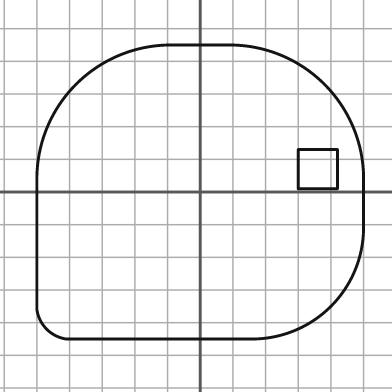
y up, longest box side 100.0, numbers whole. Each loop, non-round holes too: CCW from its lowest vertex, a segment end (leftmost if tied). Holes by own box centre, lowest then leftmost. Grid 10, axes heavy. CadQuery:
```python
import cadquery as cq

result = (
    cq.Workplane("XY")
    .moveTo(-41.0, -45.0)
    .lineTo(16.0, -45.0)
    .threePointArc((40.0, -35.0), (50.0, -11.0))
    .lineTo(50.0, 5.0)
    .threePointArc((38.0, 33.0), (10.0, 45.0))
    .lineTo(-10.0, 45.0)
    .threePointArc((-38.0, 33.0), (-50.0, 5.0))
    .lineTo(-50.0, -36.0)
    .threePointArc((-47.0, -42.0), (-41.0, -45.0))
    .close()
    .moveTo(30.0, 1.0)
    .lineTo(42.0, 1.0)
    .lineTo(42.0, 13.0)
    .lineTo(30.0, 13.0)
    .close()
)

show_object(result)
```